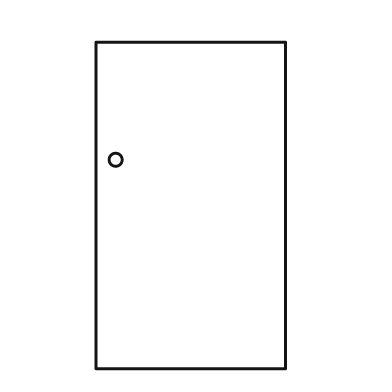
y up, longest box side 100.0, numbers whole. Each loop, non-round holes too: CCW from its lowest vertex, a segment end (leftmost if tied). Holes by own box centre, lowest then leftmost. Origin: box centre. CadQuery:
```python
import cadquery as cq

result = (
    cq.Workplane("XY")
    .moveTo(-29.0, -50.0)
    .lineTo(29.0, -50.0)
    .lineTo(29.0, 50.0)
    .lineTo(-29.0, 50.0)
    .close()
    .moveTo(-23.0, 14.0)
    .circle(2.0)
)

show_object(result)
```